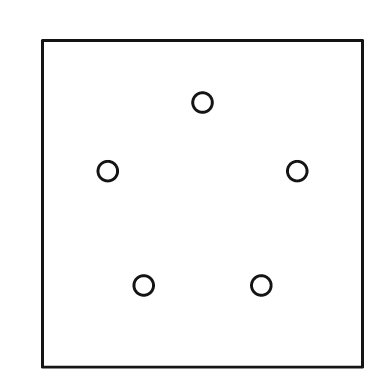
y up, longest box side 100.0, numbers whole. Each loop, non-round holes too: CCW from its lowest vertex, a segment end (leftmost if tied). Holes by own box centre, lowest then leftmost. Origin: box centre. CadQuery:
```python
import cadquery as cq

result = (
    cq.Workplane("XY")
    .moveTo(-49.0, -50.0)
    .lineTo(49.0, -50.0)
    .lineTo(49.0, 50.0)
    .lineTo(-49.0, 50.0)
    .close()
    .moveTo(-18.0, -25.0)
    .circle(3.0)
    .moveTo(18.0, -25.0)
    .circle(3.0)
    .moveTo(-29.0, 10.0)
    .circle(3.0)
    .moveTo(29.0, 10.0)
    .circle(3.0)
    .moveTo(0.0, 31.0)
    .circle(3.0)
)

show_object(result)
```